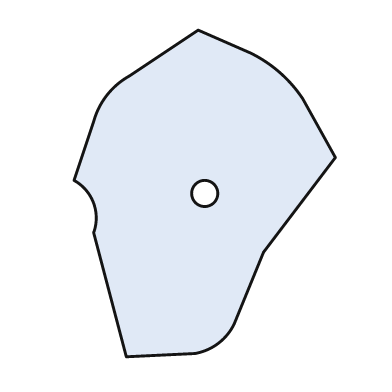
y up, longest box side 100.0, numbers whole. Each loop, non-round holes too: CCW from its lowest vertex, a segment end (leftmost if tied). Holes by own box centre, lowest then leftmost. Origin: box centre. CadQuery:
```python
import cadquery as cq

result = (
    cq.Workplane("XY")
    .moveTo(-24.0, -50.0)
    .lineTo(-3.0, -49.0)
    .threePointArc((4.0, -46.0), (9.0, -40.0))
    .lineTo(18.0, -18.0)
    .lineTo(40.0, 11.0)
    .lineTo(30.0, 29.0)
    .threePointArc((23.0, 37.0), (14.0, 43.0))
    .lineTo(-2.0, 50.0)
    .lineTo(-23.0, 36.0)
    .threePointArc((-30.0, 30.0), (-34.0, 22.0))
    .lineTo(-40.0, 4.0)
    .threePointArc((-34.0, -3.0), (-34.0, -12.0))
    .close()
    .moveTo(0.0, 0.0)
    .circle(4.0)
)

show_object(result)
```